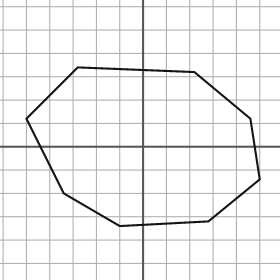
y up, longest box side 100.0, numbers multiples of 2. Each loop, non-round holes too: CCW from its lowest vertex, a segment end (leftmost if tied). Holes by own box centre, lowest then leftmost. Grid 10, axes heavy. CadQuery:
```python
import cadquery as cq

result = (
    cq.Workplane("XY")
    .moveTo(-10.0, -34.0)
    .lineTo(28.0, -32.0)
    .lineTo(50.0, -14.0)
    .lineTo(46.0, 12.0)
    .lineTo(22.0, 32.0)
    .lineTo(-28.0, 34.0)
    .lineTo(-50.0, 12.0)
    .lineTo(-34.0, -20.0)
    .close()
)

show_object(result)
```